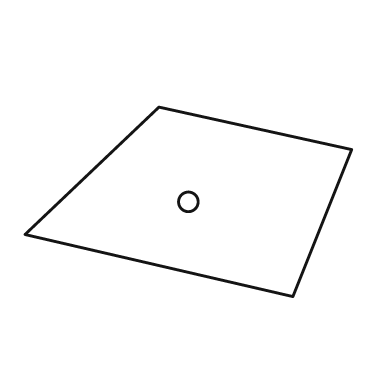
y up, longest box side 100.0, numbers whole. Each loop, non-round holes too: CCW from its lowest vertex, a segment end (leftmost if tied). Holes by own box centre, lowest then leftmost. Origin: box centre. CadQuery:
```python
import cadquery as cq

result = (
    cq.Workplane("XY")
    .moveTo(32.0, -29.0)
    .lineTo(50.0, 16.0)
    .lineTo(-9.0, 29.0)
    .lineTo(-50.0, -10.0)
    .close()
    .moveTo(0.0, 0.0)
    .circle(3.0)
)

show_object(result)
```